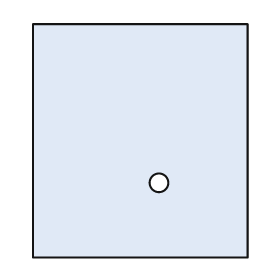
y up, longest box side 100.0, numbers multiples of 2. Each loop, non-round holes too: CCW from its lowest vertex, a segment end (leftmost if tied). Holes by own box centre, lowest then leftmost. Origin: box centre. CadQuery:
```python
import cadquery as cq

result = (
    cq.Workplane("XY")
    .moveTo(-46.0, -50.0)
    .lineTo(46.0, -50.0)
    .lineTo(46.0, 50.0)
    .lineTo(-46.0, 50.0)
    .close()
    .moveTo(8.0, -18.0)
    .circle(4.0)
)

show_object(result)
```